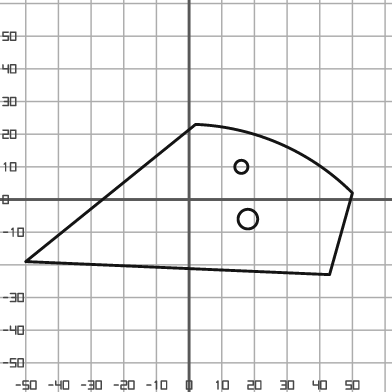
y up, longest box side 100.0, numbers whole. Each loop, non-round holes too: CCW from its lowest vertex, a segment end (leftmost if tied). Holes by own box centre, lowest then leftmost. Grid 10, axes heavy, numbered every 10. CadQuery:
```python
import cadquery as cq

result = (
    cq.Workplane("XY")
    .moveTo(43.0, -23.0)
    .lineTo(50.0, 2.0)
    .threePointArc((28.0, 17.0), (2.0, 23.0))
    .lineTo(-50.0, -19.0)
    .close()
    .moveTo(18.0, -6.0)
    .circle(3.0)
    .moveTo(16.0, 10.0)
    .circle(2.0)
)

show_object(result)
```